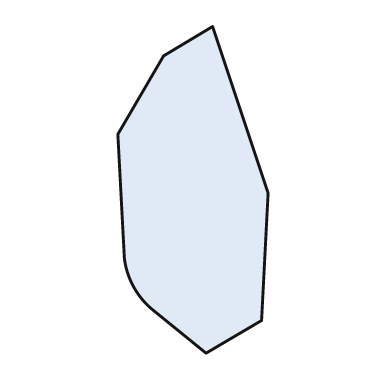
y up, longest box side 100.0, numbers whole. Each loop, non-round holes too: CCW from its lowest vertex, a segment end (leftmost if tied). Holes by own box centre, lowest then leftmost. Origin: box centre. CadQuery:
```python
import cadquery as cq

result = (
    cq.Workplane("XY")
    .moveTo(4.0, -50.0)
    .lineTo(21.0, -40.0)
    .lineTo(23.0, -1.0)
    .lineTo(6.0, 50.0)
    .lineTo(-9.0, 41.0)
    .lineTo(-23.0, 17.0)
    .lineTo(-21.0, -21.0)
    .threePointArc((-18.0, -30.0), (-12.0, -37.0))
    .close()
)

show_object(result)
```